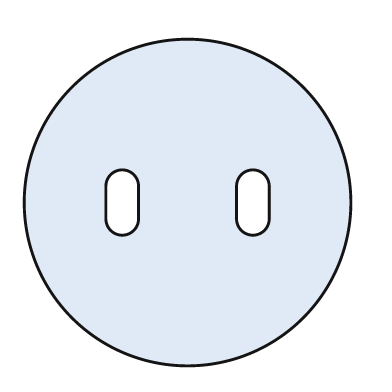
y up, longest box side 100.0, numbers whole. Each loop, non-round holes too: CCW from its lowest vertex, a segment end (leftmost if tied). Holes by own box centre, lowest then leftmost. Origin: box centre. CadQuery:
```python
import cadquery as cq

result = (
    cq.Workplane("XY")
    .moveTo(0.0, 0.0)
    .circle(50.0)
    .moveTo(-25.0, -5.0)
    .threePointArc((-20.0, -10.0), (-15.0, -5.0))
    .lineTo(-15.0, 5.0)
    .threePointArc((-20.0, 10.0), (-25.0, 5.0))
    .close()
    .moveTo(15.0, -5.0)
    .threePointArc((20.0, -10.0), (25.0, -5.0))
    .lineTo(25.0, 5.0)
    .threePointArc((20.0, 10.0), (15.0, 5.0))
    .close()
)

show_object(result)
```